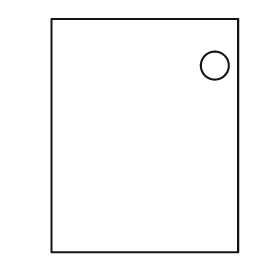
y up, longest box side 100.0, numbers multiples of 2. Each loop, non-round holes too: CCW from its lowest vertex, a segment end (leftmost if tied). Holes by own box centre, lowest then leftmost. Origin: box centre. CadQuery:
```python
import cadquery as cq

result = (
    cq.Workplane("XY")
    .moveTo(-40.0, -50.0)
    .lineTo(40.0, -50.0)
    .lineTo(40.0, 50.0)
    .lineTo(-40.0, 50.0)
    .close()
    .moveTo(30.0, 30.0)
    .circle(6.0)
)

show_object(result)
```